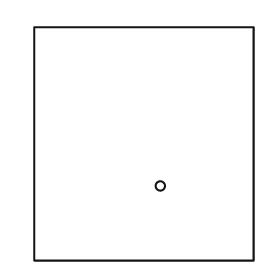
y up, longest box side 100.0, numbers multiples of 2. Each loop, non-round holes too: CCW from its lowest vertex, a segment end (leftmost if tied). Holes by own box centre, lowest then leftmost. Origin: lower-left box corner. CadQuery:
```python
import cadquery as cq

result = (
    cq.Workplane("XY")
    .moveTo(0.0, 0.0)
    .lineTo(94.0, 0.0)
    .lineTo(94.0, 100.0)
    .lineTo(0.0, 100.0)
    .close()
    .moveTo(54.0, 32.0)
    .circle(2.0)
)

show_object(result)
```